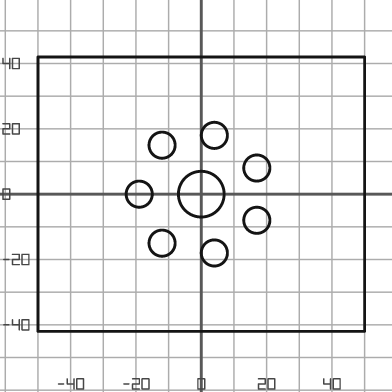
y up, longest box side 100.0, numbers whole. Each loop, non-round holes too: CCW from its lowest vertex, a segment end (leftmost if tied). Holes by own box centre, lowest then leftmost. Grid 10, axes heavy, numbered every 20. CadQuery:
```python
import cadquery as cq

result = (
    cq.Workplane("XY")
    .moveTo(-50.0, -42.0)
    .lineTo(50.0, -42.0)
    .lineTo(50.0, 42.0)
    .lineTo(-50.0, 42.0)
    .close()
    .moveTo(4.0, -18.0)
    .circle(4.0)
    .moveTo(-12.0, -15.0)
    .circle(4.0)
    .moveTo(17.0, -8.0)
    .circle(4.0)
    .moveTo(-19.0, 0.0)
    .circle(4.0)
    .moveTo(0.0, 0.0)
    .circle(7.0)
    .moveTo(17.0, 8.0)
    .circle(4.0)
    .moveTo(-12.0, 15.0)
    .circle(4.0)
    .moveTo(4.0, 18.0)
    .circle(4.0)
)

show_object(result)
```